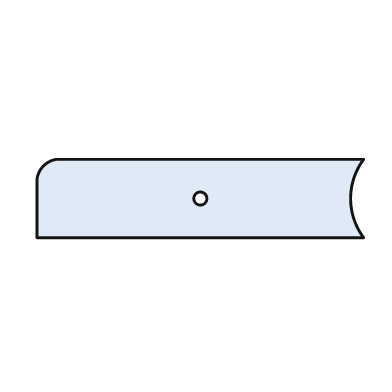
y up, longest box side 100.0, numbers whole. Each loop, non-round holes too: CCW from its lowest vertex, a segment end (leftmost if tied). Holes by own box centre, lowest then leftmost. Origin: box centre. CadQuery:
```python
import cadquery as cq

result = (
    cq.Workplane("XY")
    .moveTo(-50.0, -12.0)
    .lineTo(50.0, -12.0)
    .threePointArc((46.0, 0.0), (50.0, 12.0))
    .lineTo(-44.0, 12.0)
    .threePointArc((-48.0, 10.0), (-50.0, 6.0))
    .close()
    .moveTo(0.0, 0.0)
    .circle(2.0)
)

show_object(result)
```